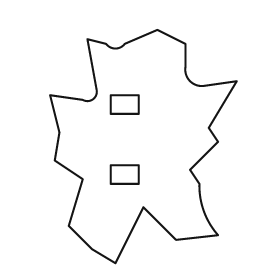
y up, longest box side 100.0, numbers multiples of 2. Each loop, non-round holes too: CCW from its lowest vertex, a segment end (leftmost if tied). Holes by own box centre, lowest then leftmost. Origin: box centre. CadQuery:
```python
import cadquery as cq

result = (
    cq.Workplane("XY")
    .moveTo(-12.0, -50.0)
    .lineTo(0.0, -26.0)
    .lineTo(14.0, -40.0)
    .lineTo(32.0, -38.0)
    .threePointArc((26.0, -28.0), (24.0, -16.0))
    .lineTo(20.0, -10.0)
    .lineTo(32.0, 2.0)
    .lineTo(28.0, 8.0)
    .lineTo(40.0, 28.0)
    .lineTo(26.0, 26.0)
    .threePointArc((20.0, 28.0), (18.0, 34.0))
    .lineTo(18.0, 44.0)
    .lineTo(6.0, 50.0)
    .lineTo(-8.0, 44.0)
    .threePointArc((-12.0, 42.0), (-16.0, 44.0))
    .lineTo(-24.0, 46.0)
    .lineTo(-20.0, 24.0)
    .threePointArc((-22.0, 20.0), (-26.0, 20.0))
    .lineTo(-40.0, 22.0)
    .lineTo(-36.0, 6.0)
    .lineTo(-38.0, -6.0)
    .lineTo(-26.0, -14.0)
    .lineTo(-32.0, -34.0)
    .lineTo(-22.0, -44.0)
    .close()
    .moveTo(-14.0, -16.0)
    .lineTo(-2.0, -16.0)
    .lineTo(-2.0, -8.0)
    .lineTo(-14.0, -8.0)
    .close()
    .moveTo(-14.0, 14.0)
    .lineTo(-2.0, 14.0)
    .lineTo(-2.0, 22.0)
    .lineTo(-14.0, 22.0)
    .close()
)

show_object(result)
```